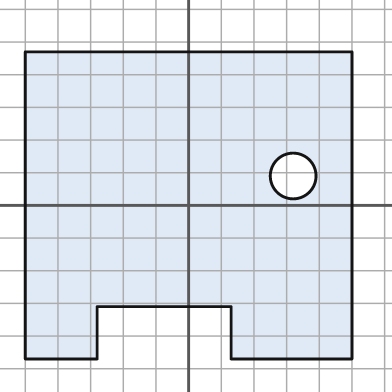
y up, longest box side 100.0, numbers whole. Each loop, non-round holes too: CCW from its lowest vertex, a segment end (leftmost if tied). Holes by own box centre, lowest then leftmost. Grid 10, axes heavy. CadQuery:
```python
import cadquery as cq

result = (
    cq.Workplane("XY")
    .moveTo(-50.0, -47.0)
    .lineTo(-28.0, -47.0)
    .lineTo(-28.0, -31.0)
    .lineTo(13.0, -31.0)
    .lineTo(13.0, -47.0)
    .lineTo(50.0, -47.0)
    .lineTo(50.0, 47.0)
    .lineTo(-50.0, 47.0)
    .close()
    .moveTo(32.0, 9.0)
    .circle(7.0)
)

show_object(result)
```